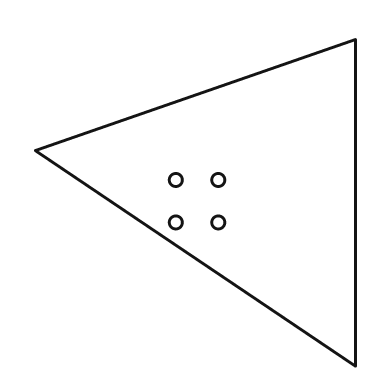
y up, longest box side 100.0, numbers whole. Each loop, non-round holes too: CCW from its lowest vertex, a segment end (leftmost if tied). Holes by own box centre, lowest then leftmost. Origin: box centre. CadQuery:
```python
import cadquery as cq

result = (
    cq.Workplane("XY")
    .moveTo(49.0, -50.0)
    .lineTo(49.0, 50.0)
    .lineTo(-49.0, 16.0)
    .close()
    .moveTo(-6.0, -6.0)
    .circle(2.0)
    .moveTo(7.0, -6.0)
    .circle(2.0)
    .moveTo(-6.0, 7.0)
    .circle(2.0)
    .moveTo(7.0, 7.0)
    .circle(2.0)
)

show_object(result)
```